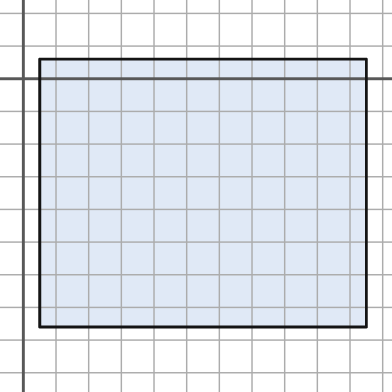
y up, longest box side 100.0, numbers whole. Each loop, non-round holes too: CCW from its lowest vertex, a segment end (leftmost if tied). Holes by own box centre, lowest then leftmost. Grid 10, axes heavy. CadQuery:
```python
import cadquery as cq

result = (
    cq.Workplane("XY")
    .moveTo(5.0, -76.0)
    .lineTo(105.0, -76.0)
    .lineTo(105.0, 6.0)
    .lineTo(5.0, 6.0)
    .close()
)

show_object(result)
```